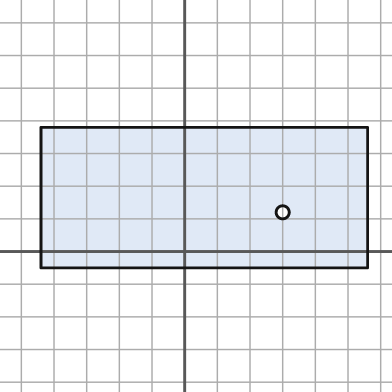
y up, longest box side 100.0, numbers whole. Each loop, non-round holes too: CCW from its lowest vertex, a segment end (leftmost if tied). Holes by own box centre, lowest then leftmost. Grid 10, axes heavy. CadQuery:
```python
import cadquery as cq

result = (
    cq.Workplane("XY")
    .moveTo(-44.0, -5.0)
    .lineTo(56.0, -5.0)
    .lineTo(56.0, 38.0)
    .lineTo(-44.0, 38.0)
    .close()
    .moveTo(30.0, 12.0)
    .circle(2.0)
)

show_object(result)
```